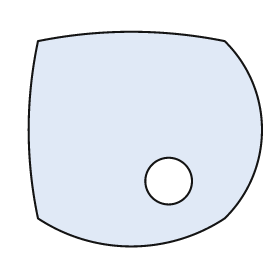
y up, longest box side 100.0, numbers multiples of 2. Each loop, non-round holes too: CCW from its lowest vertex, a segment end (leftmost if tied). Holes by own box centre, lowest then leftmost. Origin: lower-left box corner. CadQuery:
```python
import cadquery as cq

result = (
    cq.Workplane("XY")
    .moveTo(4.0, 12.0)
    .threePointArc((44.0, 0.0), (84.0, 12.0))
    .threePointArc((100.0, 50.0), (84.0, 88.0))
    .threePointArc((44.0, 92.0), (4.0, 88.0))
    .threePointArc((0.0, 50.0), (4.0, 12.0))
    .close()
    .moveTo(60.0, 28.0)
    .circle(10.0)
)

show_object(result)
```